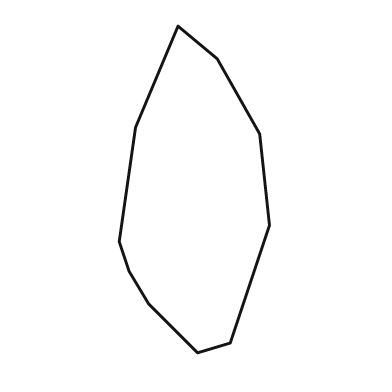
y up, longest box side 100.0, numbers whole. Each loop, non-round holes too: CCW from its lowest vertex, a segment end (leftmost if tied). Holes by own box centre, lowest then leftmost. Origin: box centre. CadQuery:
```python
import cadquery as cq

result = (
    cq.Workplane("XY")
    .moveTo(1.0, -50.0)
    .lineTo(11.0, -47.0)
    .lineTo(23.0, -11.0)
    .lineTo(20.0, 17.0)
    .lineTo(7.0, 40.0)
    .lineTo(-5.0, 50.0)
    .lineTo(-18.0, 19.0)
    .lineTo(-23.0, -16.0)
    .lineTo(-20.0, -25.0)
    .lineTo(-14.0, -35.0)
    .close()
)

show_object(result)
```